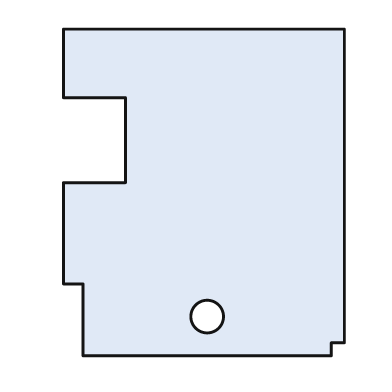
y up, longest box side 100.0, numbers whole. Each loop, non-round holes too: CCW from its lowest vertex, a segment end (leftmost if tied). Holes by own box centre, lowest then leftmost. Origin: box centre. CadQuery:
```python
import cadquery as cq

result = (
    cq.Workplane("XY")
    .moveTo(-37.0, -50.0)
    .lineTo(39.0, -50.0)
    .lineTo(39.0, -46.0)
    .lineTo(43.0, -46.0)
    .lineTo(43.0, 50.0)
    .lineTo(-43.0, 50.0)
    .lineTo(-43.0, 29.0)
    .lineTo(-24.0, 29.0)
    .lineTo(-24.0, 3.0)
    .lineTo(-43.0, 3.0)
    .lineTo(-43.0, -28.0)
    .lineTo(-37.0, -28.0)
    .close()
    .moveTo(1.0, -38.0)
    .circle(5.0)
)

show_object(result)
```